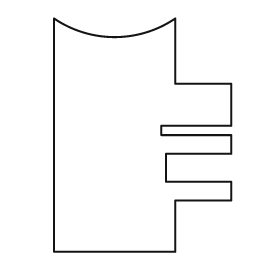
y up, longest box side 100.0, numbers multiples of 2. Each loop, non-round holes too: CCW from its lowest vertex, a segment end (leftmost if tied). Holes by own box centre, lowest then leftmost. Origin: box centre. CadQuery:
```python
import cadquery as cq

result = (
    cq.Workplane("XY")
    .moveTo(-38.0, -50.0)
    .lineTo(14.0, -50.0)
    .lineTo(14.0, -28.0)
    .lineTo(38.0, -28.0)
    .lineTo(38.0, -20.0)
    .lineTo(10.0, -20.0)
    .lineTo(10.0, -8.0)
    .lineTo(38.0, -8.0)
    .lineTo(38.0, 0.0)
    .lineTo(8.0, 0.0)
    .lineTo(8.0, 4.0)
    .lineTo(38.0, 4.0)
    .lineTo(38.0, 22.0)
    .lineTo(14.0, 22.0)
    .lineTo(14.0, 50.0)
    .threePointArc((-12.0, 42.0), (-38.0, 50.0))
    .close()
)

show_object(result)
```